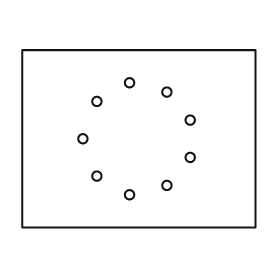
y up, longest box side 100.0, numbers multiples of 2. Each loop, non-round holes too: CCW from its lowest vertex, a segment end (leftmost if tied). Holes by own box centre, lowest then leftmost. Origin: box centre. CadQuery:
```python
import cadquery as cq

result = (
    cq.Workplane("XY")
    .moveTo(-50.0, -38.0)
    .lineTo(50.0, -38.0)
    .lineTo(50.0, 38.0)
    .lineTo(-50.0, 38.0)
    .close()
    .moveTo(-4.0, -24.0)
    .circle(2.0)
    .moveTo(12.0, -20.0)
    .circle(2.0)
    .moveTo(-18.0, -16.0)
    .circle(2.0)
    .moveTo(22.0, -8.0)
    .circle(2.0)
    .moveTo(-24.0, 0.0)
    .circle(2.0)
    .moveTo(22.0, 8.0)
    .circle(2.0)
    .moveTo(-18.0, 16.0)
    .circle(2.0)
    .moveTo(12.0, 20.0)
    .circle(2.0)
    .moveTo(-4.0, 24.0)
    .circle(2.0)
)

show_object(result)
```